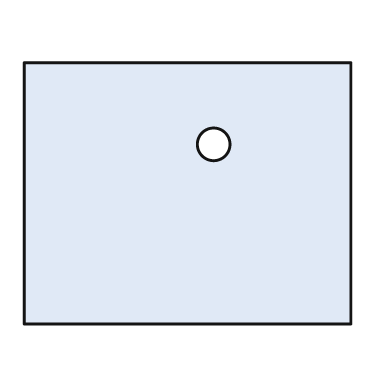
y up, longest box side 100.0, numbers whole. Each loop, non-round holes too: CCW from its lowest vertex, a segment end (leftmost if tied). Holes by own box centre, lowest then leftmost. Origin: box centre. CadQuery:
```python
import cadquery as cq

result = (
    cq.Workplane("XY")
    .moveTo(-50.0, -40.0)
    .lineTo(50.0, -40.0)
    .lineTo(50.0, 40.0)
    .lineTo(-50.0, 40.0)
    .close()
    .moveTo(8.0, 15.0)
    .circle(5.0)
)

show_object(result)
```